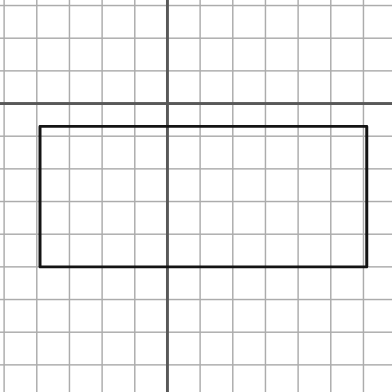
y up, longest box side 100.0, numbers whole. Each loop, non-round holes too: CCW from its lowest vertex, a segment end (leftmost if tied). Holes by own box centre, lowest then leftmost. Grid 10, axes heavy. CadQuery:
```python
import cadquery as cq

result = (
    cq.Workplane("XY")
    .moveTo(-39.0, -50.0)
    .lineTo(61.0, -50.0)
    .lineTo(61.0, -7.0)
    .lineTo(-39.0, -7.0)
    .close()
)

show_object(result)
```